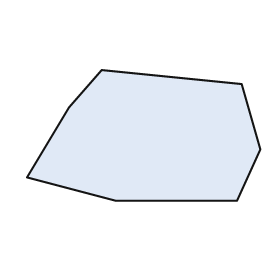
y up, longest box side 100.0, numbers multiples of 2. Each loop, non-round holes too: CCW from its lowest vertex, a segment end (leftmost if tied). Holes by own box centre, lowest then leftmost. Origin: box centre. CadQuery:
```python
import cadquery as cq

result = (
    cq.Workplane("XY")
    .moveTo(-12.0, -28.0)
    .lineTo(40.0, -28.0)
    .lineTo(50.0, -6.0)
    .lineTo(42.0, 22.0)
    .lineTo(-18.0, 28.0)
    .lineTo(-32.0, 12.0)
    .lineTo(-50.0, -18.0)
    .close()
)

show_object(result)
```